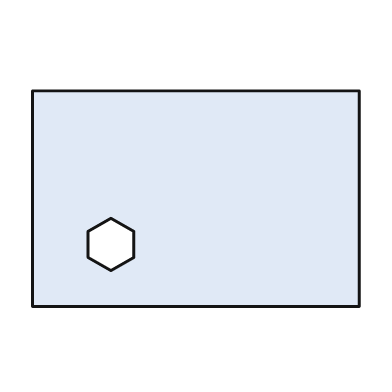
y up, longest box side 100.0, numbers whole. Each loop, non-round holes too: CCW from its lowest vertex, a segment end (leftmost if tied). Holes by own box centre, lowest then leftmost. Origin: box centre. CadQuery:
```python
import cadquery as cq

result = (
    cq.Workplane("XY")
    .moveTo(-50.0, -33.0)
    .lineTo(50.0, -33.0)
    .lineTo(50.0, 33.0)
    .lineTo(-50.0, 33.0)
    .close()
    .moveTo(-26.0, -22.0)
    .lineTo(-19.0, -18.0)
    .lineTo(-19.0, -10.0)
    .lineTo(-26.0, -6.0)
    .lineTo(-33.0, -10.0)
    .lineTo(-33.0, -18.0)
    .close()
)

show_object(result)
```